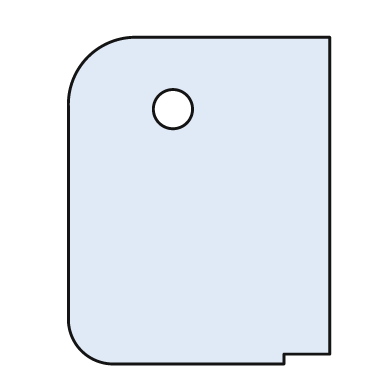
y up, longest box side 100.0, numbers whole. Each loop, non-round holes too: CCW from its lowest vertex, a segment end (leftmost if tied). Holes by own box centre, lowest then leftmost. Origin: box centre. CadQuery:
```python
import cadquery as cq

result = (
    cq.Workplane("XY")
    .moveTo(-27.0, -50.0)
    .lineTo(26.0, -50.0)
    .lineTo(26.0, -47.0)
    .lineTo(40.0, -47.0)
    .lineTo(40.0, 50.0)
    .lineTo(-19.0, 50.0)
    .threePointArc((-34.0, 44.0), (-40.0, 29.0))
    .lineTo(-40.0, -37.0)
    .threePointArc((-36.0, -46.0), (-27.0, -50.0))
    .close()
    .moveTo(-8.0, 28.0)
    .circle(6.0)
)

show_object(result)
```